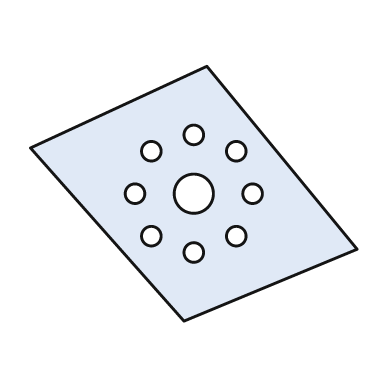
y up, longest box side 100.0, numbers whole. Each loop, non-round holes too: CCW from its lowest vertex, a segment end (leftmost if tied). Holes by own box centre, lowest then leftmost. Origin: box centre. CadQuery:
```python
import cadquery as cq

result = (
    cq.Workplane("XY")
    .moveTo(-3.0, -39.0)
    .lineTo(50.0, -17.0)
    .lineTo(4.0, 39.0)
    .lineTo(-50.0, 14.0)
    .close()
    .moveTo(0.0, -18.0)
    .circle(3.0)
    .moveTo(-13.0, -13.0)
    .circle(3.0)
    .moveTo(13.0, -13.0)
    .circle(3.0)
    .moveTo(-18.0, 0.0)
    .circle(3.0)
    .moveTo(0.0, 0.0)
    .circle(6.0)
    .moveTo(18.0, 0.0)
    .circle(3.0)
    .moveTo(-13.0, 13.0)
    .circle(3.0)
    .moveTo(13.0, 13.0)
    .circle(3.0)
    .moveTo(0.0, 18.0)
    .circle(3.0)
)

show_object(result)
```